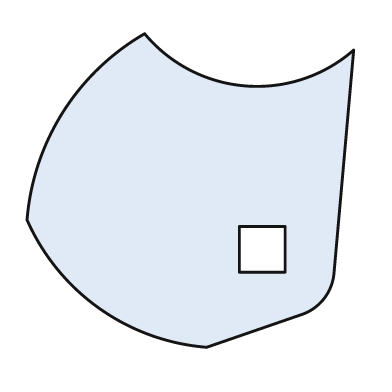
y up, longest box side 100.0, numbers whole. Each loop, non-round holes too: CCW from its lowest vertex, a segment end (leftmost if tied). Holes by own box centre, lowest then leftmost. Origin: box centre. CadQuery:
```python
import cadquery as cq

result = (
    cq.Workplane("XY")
    .moveTo(5.0, -48.0)
    .lineTo(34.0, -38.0)
    .threePointArc((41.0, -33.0), (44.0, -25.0))
    .lineTo(50.0, 43.0)
    .threePointArc((17.0, 32.0), (-14.0, 48.0))
    .threePointArc((-39.0, 24.0), (-50.0, -9.0))
    .threePointArc((-28.0, -36.0), (5.0, -48.0))
    .close()
    .moveTo(15.0, -25.0)
    .lineTo(29.0, -25.0)
    .lineTo(29.0, -11.0)
    .lineTo(15.0, -11.0)
    .close()
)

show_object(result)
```